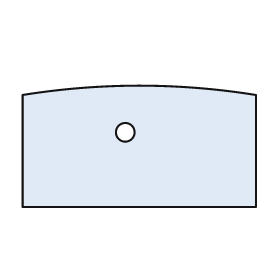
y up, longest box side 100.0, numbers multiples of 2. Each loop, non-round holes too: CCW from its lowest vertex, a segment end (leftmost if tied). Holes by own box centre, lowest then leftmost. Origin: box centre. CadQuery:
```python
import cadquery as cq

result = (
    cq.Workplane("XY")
    .moveTo(-50.0, -26.0)
    .lineTo(50.0, -26.0)
    .lineTo(50.0, 22.0)
    .threePointArc((0.0, 26.0), (-50.0, 22.0))
    .close()
    .moveTo(-6.0, 6.0)
    .circle(4.0)
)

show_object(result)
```